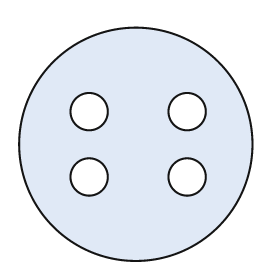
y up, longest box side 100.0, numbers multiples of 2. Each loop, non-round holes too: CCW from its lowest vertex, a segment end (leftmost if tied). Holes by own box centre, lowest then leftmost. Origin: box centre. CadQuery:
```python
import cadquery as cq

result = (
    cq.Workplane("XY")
    .moveTo(0.0, 0.0)
    .circle(50.0)
    .moveTo(-20.0, -14.0)
    .circle(8.0)
    .moveTo(22.0, -14.0)
    .circle(8.0)
    .moveTo(-20.0, 14.0)
    .circle(8.0)
    .moveTo(22.0, 14.0)
    .circle(8.0)
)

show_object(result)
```